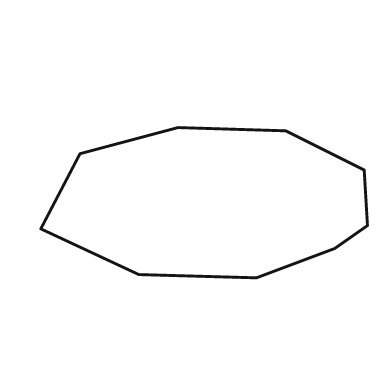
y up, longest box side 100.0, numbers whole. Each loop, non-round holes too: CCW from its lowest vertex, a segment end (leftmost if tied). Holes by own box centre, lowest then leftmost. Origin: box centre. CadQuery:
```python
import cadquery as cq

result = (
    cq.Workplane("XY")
    .moveTo(16.0, -23.0)
    .lineTo(40.0, -14.0)
    .lineTo(50.0, -7.0)
    .lineTo(49.0, 10.0)
    .lineTo(25.0, 22.0)
    .lineTo(-8.0, 23.0)
    .lineTo(-38.0, 15.0)
    .lineTo(-50.0, -8.0)
    .lineTo(-20.0, -22.0)
    .close()
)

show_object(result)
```